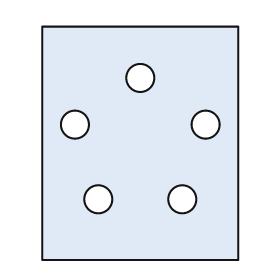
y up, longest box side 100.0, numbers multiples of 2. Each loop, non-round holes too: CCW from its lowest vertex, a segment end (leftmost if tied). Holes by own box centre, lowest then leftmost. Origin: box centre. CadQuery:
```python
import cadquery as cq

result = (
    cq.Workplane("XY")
    .moveTo(-42.0, -50.0)
    .lineTo(42.0, -50.0)
    .lineTo(42.0, 50.0)
    .lineTo(-42.0, 50.0)
    .close()
    .moveTo(-18.0, -24.0)
    .circle(6.0)
    .moveTo(18.0, -24.0)
    .circle(6.0)
    .moveTo(-28.0, 8.0)
    .circle(6.0)
    .moveTo(28.0, 8.0)
    .circle(6.0)
    .moveTo(0.0, 28.0)
    .circle(6.0)
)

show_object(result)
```